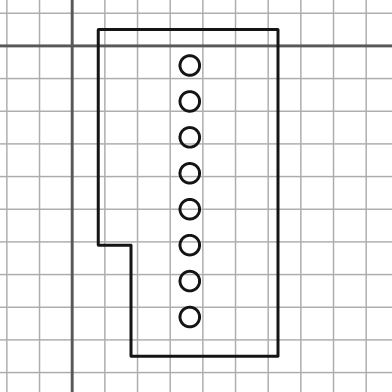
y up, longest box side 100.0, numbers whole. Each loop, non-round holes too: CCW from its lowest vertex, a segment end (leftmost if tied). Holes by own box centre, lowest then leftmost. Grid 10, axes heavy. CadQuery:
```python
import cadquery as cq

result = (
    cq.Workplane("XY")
    .moveTo(18.0, -95.0)
    .lineTo(63.0, -95.0)
    .lineTo(63.0, 5.0)
    .lineTo(8.0, 5.0)
    .lineTo(8.0, -61.0)
    .lineTo(18.0, -61.0)
    .close()
    .moveTo(36.0, -83.0)
    .circle(3.0)
    .moveTo(36.0, -72.0)
    .circle(3.0)
    .moveTo(36.0, -61.0)
    .circle(3.0)
    .moveTo(36.0, -50.0)
    .circle(3.0)
    .moveTo(36.0, -39.0)
    .circle(3.0)
    .moveTo(36.0, -28.0)
    .circle(3.0)
    .moveTo(36.0, -17.0)
    .circle(3.0)
    .moveTo(36.0, -6.0)
    .circle(3.0)
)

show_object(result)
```